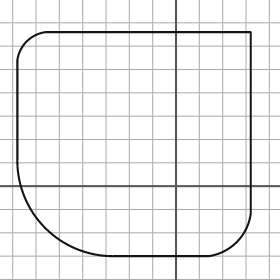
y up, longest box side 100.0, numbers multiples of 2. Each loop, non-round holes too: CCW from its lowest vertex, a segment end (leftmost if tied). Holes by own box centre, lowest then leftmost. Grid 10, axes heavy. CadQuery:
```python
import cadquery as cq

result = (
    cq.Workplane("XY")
    .moveTo(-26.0, -30.0)
    .lineTo(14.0, -30.0)
    .threePointArc((26.0, -24.0), (32.0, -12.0))
    .lineTo(32.0, 66.0)
    .lineTo(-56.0, 66.0)
    .threePointArc((-64.0, 62.0), (-68.0, 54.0))
    .lineTo(-68.0, 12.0)
    .threePointArc((-56.0, -18.0), (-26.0, -30.0))
    .close()
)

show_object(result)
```